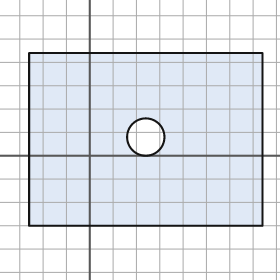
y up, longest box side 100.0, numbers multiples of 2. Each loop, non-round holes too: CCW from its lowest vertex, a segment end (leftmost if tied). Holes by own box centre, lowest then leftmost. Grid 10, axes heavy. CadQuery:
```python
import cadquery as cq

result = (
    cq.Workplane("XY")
    .moveTo(-26.0, -30.0)
    .lineTo(74.0, -30.0)
    .lineTo(74.0, 44.0)
    .lineTo(-26.0, 44.0)
    .close()
    .moveTo(24.0, 8.0)
    .circle(8.0)
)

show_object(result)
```